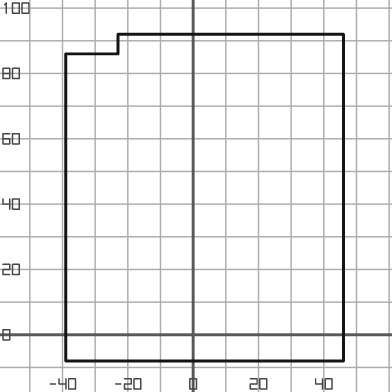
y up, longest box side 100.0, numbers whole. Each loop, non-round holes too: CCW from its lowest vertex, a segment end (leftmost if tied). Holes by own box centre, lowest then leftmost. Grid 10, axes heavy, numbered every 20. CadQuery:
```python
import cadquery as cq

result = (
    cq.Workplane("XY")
    .moveTo(-39.0, -8.0)
    .lineTo(46.0, -8.0)
    .lineTo(46.0, 92.0)
    .lineTo(-23.0, 92.0)
    .lineTo(-23.0, 86.0)
    .lineTo(-39.0, 86.0)
    .close()
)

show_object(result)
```